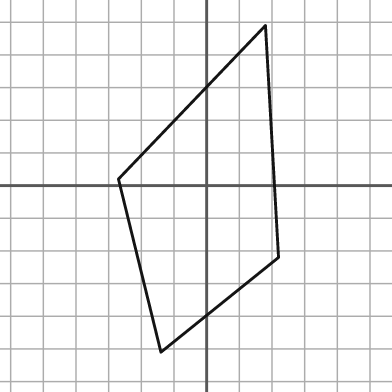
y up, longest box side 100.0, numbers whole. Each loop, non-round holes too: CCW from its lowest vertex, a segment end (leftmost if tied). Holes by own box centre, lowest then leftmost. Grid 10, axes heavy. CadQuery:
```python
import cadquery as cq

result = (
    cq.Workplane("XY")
    .moveTo(-14.0, -51.0)
    .lineTo(22.0, -22.0)
    .lineTo(18.0, 49.0)
    .lineTo(-27.0, 2.0)
    .close()
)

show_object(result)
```